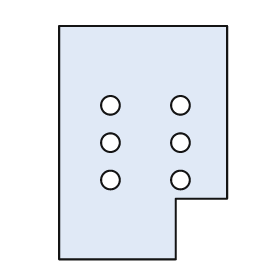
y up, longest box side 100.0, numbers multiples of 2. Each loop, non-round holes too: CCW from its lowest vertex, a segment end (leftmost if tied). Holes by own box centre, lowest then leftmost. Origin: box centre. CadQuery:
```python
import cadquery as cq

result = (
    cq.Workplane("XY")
    .moveTo(-36.0, -50.0)
    .lineTo(14.0, -50.0)
    .lineTo(14.0, -24.0)
    .lineTo(36.0, -24.0)
    .lineTo(36.0, 50.0)
    .lineTo(-36.0, 50.0)
    .close()
    .moveTo(-14.0, -16.0)
    .circle(4.0)
    .moveTo(16.0, -16.0)
    .circle(4.0)
    .moveTo(-14.0, 0.0)
    .circle(4.0)
    .moveTo(16.0, 0.0)
    .circle(4.0)
    .moveTo(-14.0, 16.0)
    .circle(4.0)
    .moveTo(16.0, 16.0)
    .circle(4.0)
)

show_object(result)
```